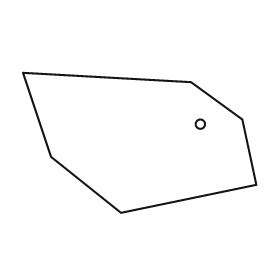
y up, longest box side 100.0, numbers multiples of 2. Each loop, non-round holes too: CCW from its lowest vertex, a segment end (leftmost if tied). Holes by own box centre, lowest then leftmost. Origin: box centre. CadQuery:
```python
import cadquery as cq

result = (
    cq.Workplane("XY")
    .moveTo(-8.0, -30.0)
    .lineTo(50.0, -18.0)
    .lineTo(44.0, 10.0)
    .lineTo(22.0, 26.0)
    .lineTo(-50.0, 30.0)
    .lineTo(-38.0, -6.0)
    .close()
    .moveTo(26.0, 8.0)
    .circle(2.0)
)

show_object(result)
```